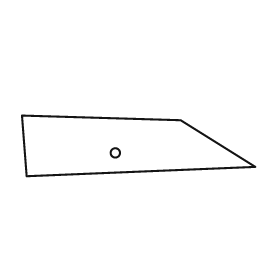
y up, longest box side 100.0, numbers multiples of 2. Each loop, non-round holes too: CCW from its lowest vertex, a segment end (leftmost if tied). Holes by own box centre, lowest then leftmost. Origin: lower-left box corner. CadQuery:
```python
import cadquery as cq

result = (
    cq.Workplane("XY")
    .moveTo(2.0, 0.0)
    .lineTo(100.0, 4.0)
    .lineTo(68.0, 24.0)
    .lineTo(0.0, 26.0)
    .close()
    .moveTo(40.0, 10.0)
    .circle(2.0)
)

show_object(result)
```